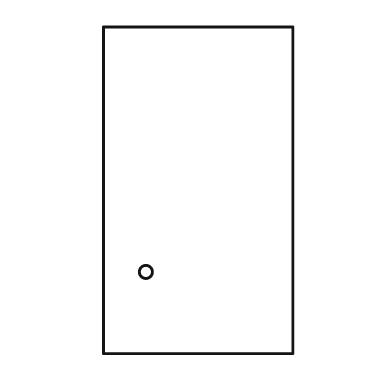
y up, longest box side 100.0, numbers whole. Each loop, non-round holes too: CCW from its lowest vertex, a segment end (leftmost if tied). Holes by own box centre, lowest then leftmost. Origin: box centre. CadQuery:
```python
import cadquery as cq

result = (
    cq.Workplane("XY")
    .moveTo(-29.0, -50.0)
    .lineTo(29.0, -50.0)
    .lineTo(29.0, 50.0)
    .lineTo(-29.0, 50.0)
    .close()
    .moveTo(-16.0, -25.0)
    .circle(2.0)
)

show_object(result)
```